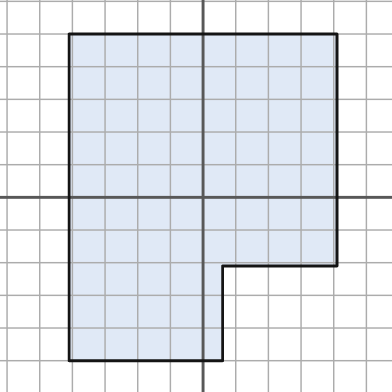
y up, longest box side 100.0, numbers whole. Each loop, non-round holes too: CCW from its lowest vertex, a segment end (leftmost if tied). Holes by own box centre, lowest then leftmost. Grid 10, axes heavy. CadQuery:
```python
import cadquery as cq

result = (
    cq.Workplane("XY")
    .moveTo(-41.0, -50.0)
    .lineTo(6.0, -50.0)
    .lineTo(6.0, -21.0)
    .lineTo(41.0, -21.0)
    .lineTo(41.0, 50.0)
    .lineTo(-41.0, 50.0)
    .close()
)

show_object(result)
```